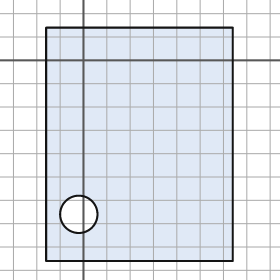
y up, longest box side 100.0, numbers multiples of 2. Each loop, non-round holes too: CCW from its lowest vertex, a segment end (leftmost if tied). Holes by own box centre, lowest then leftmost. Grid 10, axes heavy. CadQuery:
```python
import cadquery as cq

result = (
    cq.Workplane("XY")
    .moveTo(-16.0, -86.0)
    .lineTo(64.0, -86.0)
    .lineTo(64.0, 14.0)
    .lineTo(-16.0, 14.0)
    .close()
    .moveTo(-2.0, -66.0)
    .circle(8.0)
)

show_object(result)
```